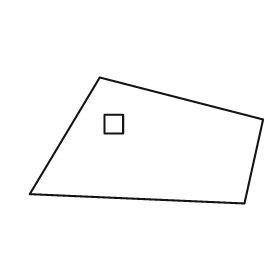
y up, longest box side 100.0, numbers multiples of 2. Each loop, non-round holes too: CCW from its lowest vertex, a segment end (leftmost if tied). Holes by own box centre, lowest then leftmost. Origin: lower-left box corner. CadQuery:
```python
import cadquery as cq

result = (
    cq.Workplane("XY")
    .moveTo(92.0, 0.0)
    .lineTo(100.0, 36.0)
    .lineTo(30.0, 54.0)
    .lineTo(0.0, 4.0)
    .close()
    .moveTo(32.0, 30.0)
    .lineTo(40.0, 30.0)
    .lineTo(40.0, 38.0)
    .lineTo(32.0, 38.0)
    .close()
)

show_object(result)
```